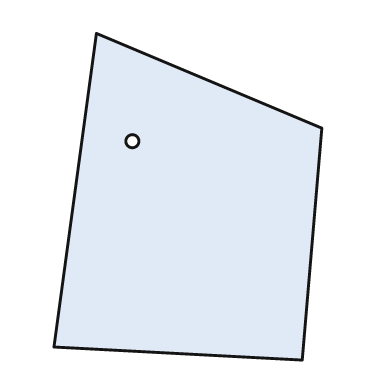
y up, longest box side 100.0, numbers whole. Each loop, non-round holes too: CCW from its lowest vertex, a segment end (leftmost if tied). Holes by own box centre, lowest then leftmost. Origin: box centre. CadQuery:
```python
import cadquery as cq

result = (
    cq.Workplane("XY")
    .moveTo(35.0, -50.0)
    .lineTo(41.0, 21.0)
    .lineTo(-28.0, 50.0)
    .lineTo(-41.0, -46.0)
    .close()
    .moveTo(-17.0, 17.0)
    .circle(2.0)
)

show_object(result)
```